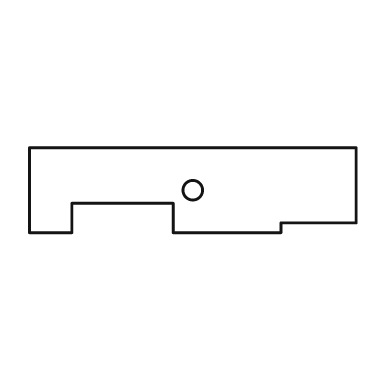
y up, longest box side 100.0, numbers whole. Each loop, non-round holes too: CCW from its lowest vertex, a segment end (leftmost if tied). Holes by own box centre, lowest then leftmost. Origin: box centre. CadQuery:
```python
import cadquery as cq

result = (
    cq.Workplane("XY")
    .moveTo(-50.0, -13.0)
    .lineTo(-37.0, -13.0)
    .lineTo(-37.0, -4.0)
    .lineTo(-6.0, -4.0)
    .lineTo(-6.0, -13.0)
    .lineTo(27.0, -13.0)
    .lineTo(27.0, -10.0)
    .lineTo(50.0, -10.0)
    .lineTo(50.0, 13.0)
    .lineTo(-50.0, 13.0)
    .close()
    .moveTo(0.0, 0.0)
    .circle(3.0)
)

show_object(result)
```